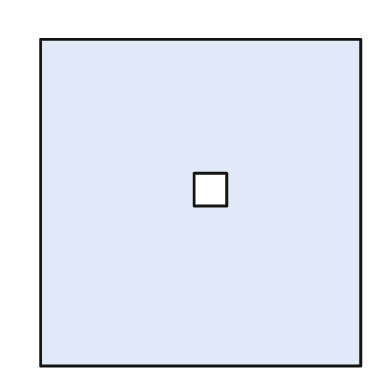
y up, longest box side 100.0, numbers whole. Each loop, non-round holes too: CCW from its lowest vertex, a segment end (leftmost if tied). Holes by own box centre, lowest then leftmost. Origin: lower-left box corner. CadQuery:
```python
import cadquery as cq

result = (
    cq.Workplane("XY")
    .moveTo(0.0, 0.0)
    .lineTo(98.0, 0.0)
    .lineTo(98.0, 100.0)
    .lineTo(0.0, 100.0)
    .close()
    .moveTo(47.0, 49.0)
    .lineTo(57.0, 49.0)
    .lineTo(57.0, 59.0)
    .lineTo(47.0, 59.0)
    .close()
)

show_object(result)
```